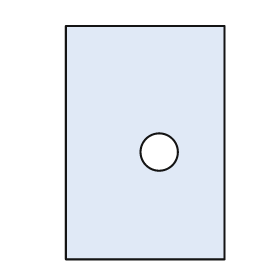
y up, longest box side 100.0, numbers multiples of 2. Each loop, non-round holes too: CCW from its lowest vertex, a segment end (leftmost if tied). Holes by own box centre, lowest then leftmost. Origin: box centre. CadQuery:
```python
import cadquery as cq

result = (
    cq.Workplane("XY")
    .moveTo(-34.0, -50.0)
    .lineTo(34.0, -50.0)
    .lineTo(34.0, 50.0)
    .lineTo(-34.0, 50.0)
    .close()
    .moveTo(6.0, -4.0)
    .circle(8.0)
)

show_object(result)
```